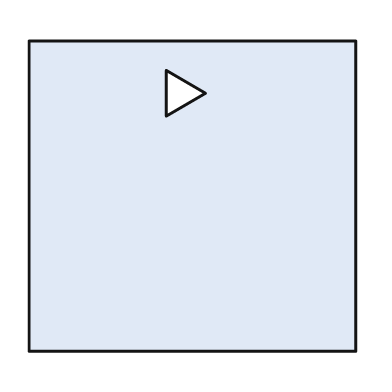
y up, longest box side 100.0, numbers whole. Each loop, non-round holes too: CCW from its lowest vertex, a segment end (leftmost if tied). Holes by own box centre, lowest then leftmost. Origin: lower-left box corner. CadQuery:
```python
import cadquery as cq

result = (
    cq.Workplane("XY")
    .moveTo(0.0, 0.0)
    .lineTo(100.0, 0.0)
    .lineTo(100.0, 95.0)
    .lineTo(0.0, 95.0)
    .close()
    .moveTo(42.0, 72.0)
    .lineTo(54.0, 79.0)
    .lineTo(42.0, 86.0)
    .close()
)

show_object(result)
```